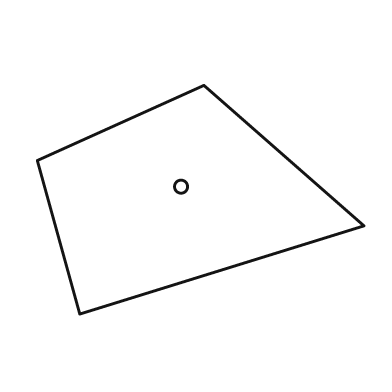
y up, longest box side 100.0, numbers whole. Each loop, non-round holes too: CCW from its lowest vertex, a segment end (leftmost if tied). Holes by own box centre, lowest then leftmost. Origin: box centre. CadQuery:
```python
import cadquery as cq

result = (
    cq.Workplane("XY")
    .moveTo(-37.0, -35.0)
    .lineTo(50.0, -8.0)
    .lineTo(1.0, 35.0)
    .lineTo(-50.0, 12.0)
    .close()
    .moveTo(-6.0, 4.0)
    .circle(2.0)
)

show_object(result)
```